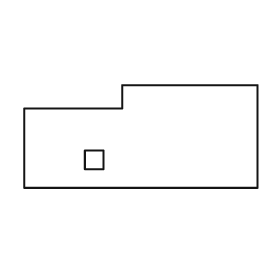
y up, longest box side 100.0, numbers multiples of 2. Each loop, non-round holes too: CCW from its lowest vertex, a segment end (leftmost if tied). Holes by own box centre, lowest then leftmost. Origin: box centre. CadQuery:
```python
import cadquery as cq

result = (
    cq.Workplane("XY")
    .moveTo(-50.0, -22.0)
    .lineTo(50.0, -22.0)
    .lineTo(50.0, 22.0)
    .lineTo(-8.0, 22.0)
    .lineTo(-8.0, 12.0)
    .lineTo(-50.0, 12.0)
    .close()
    .moveTo(-24.0, -14.0)
    .lineTo(-16.0, -14.0)
    .lineTo(-16.0, -6.0)
    .lineTo(-24.0, -6.0)
    .close()
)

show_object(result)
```